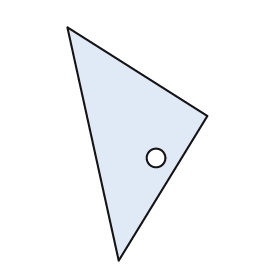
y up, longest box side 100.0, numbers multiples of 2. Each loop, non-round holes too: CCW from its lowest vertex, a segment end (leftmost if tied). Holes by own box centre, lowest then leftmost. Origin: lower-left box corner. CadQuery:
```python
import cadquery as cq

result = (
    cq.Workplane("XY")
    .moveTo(22.0, 0.0)
    .lineTo(60.0, 62.0)
    .lineTo(0.0, 100.0)
    .close()
    .moveTo(38.0, 44.0)
    .circle(4.0)
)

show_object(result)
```